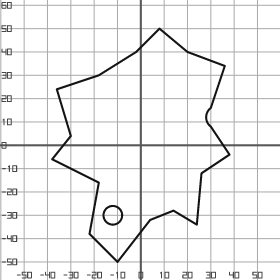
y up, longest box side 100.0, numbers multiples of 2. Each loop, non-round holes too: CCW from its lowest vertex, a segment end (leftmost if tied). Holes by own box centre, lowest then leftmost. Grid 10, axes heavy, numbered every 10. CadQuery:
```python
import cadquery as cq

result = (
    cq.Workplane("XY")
    .moveTo(-10.0, -50.0)
    .lineTo(4.0, -32.0)
    .lineTo(14.0, -28.0)
    .lineTo(24.0, -34.0)
    .lineTo(26.0, -12.0)
    .lineTo(38.0, -4.0)
    .lineTo(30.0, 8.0)
    .threePointArc((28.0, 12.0), (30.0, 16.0))
    .lineTo(36.0, 34.0)
    .lineTo(20.0, 40.0)
    .lineTo(8.0, 50.0)
    .lineTo(-2.0, 40.0)
    .lineTo(-18.0, 30.0)
    .lineTo(-36.0, 24.0)
    .lineTo(-30.0, 4.0)
    .lineTo(-38.0, -6.0)
    .lineTo(-18.0, -16.0)
    .lineTo(-22.0, -38.0)
    .close()
    .moveTo(-12.0, -30.0)
    .circle(4.0)
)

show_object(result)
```